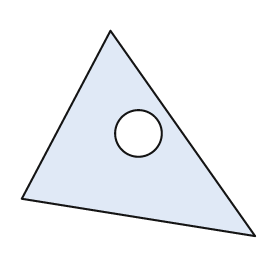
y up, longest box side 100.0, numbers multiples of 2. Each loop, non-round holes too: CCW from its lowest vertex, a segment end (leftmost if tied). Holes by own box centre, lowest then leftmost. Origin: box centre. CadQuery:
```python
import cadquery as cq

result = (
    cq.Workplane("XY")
    .moveTo(50.0, -44.0)
    .lineTo(-12.0, 44.0)
    .lineTo(-50.0, -28.0)
    .close()
    .moveTo(0.0, 0.0)
    .circle(10.0)
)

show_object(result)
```